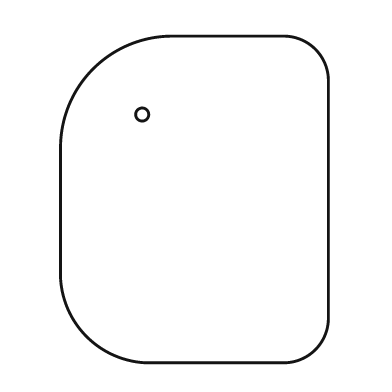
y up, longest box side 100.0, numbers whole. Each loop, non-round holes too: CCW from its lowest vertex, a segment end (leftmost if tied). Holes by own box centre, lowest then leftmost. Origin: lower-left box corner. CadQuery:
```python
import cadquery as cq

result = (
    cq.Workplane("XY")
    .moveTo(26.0, 0.0)
    .lineTo(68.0, 0.0)
    .threePointArc((78.0, 4.0), (82.0, 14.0))
    .lineTo(82.0, 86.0)
    .threePointArc((78.0, 96.0), (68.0, 100.0))
    .lineTo(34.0, 100.0)
    .threePointArc((10.0, 90.0), (0.0, 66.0))
    .lineTo(0.0, 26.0)
    .threePointArc((8.0, 8.0), (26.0, 0.0))
    .close()
    .moveTo(25.0, 76.0)
    .circle(2.0)
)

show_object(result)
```